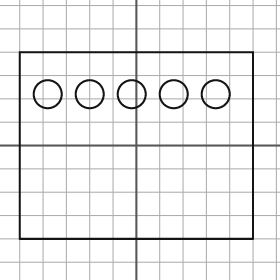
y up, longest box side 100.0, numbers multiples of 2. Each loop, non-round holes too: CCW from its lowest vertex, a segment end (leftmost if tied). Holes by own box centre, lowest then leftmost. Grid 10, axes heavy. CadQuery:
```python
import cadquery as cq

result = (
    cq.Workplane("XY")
    .moveTo(-50.0, -40.0)
    .lineTo(50.0, -40.0)
    .lineTo(50.0, 40.0)
    .lineTo(-50.0, 40.0)
    .close()
    .moveTo(-38.0, 22.0)
    .circle(6.0)
    .moveTo(-20.0, 22.0)
    .circle(6.0)
    .moveTo(-2.0, 22.0)
    .circle(6.0)
    .moveTo(16.0, 22.0)
    .circle(6.0)
    .moveTo(34.0, 22.0)
    .circle(6.0)
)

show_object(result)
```